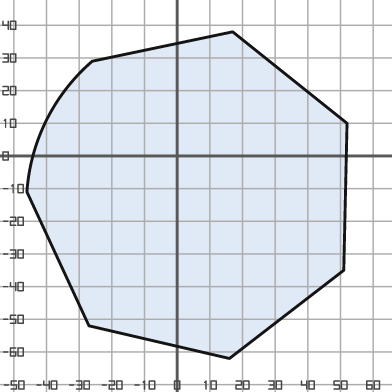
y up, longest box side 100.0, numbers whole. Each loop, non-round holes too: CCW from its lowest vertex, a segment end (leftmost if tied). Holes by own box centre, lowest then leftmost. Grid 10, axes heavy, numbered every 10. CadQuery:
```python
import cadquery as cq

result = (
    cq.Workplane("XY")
    .moveTo(16.0, -62.0)
    .lineTo(51.0, -35.0)
    .lineTo(52.0, 10.0)
    .lineTo(17.0, 38.0)
    .lineTo(-26.0, 29.0)
    .threePointArc((-40.0, 11.0), (-46.0, -11.0))
    .lineTo(-27.0, -52.0)
    .close()
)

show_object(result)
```